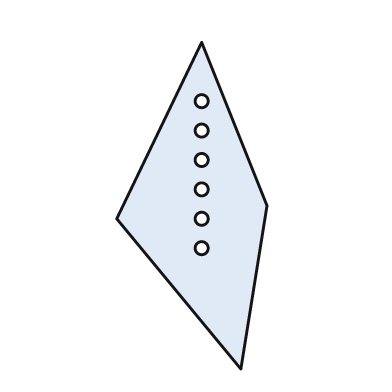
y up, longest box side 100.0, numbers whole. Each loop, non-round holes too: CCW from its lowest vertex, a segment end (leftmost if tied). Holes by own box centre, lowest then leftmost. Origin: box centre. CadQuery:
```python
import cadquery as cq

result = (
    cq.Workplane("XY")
    .moveTo(15.0, -50.0)
    .lineTo(23.0, 0.0)
    .lineTo(3.0, 50.0)
    .lineTo(-23.0, -4.0)
    .close()
    .moveTo(3.0, -13.0)
    .circle(2.0)
    .moveTo(3.0, -4.0)
    .circle(2.0)
    .moveTo(3.0, 5.0)
    .circle(2.0)
    .moveTo(3.0, 14.0)
    .circle(2.0)
    .moveTo(3.0, 23.0)
    .circle(2.0)
    .moveTo(3.0, 32.0)
    .circle(2.0)
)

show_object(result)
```